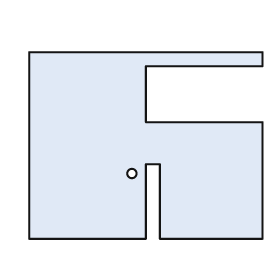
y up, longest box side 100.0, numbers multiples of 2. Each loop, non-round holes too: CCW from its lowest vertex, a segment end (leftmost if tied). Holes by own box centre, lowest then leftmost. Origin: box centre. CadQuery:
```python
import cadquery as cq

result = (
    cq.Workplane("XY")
    .moveTo(-50.0, -40.0)
    .lineTo(0.0, -40.0)
    .lineTo(0.0, -8.0)
    .lineTo(6.0, -8.0)
    .lineTo(6.0, -40.0)
    .lineTo(50.0, -40.0)
    .lineTo(50.0, 10.0)
    .lineTo(0.0, 10.0)
    .lineTo(0.0, 34.0)
    .lineTo(50.0, 34.0)
    .lineTo(50.0, 40.0)
    .lineTo(-50.0, 40.0)
    .close()
    .moveTo(-6.0, -12.0)
    .circle(2.0)
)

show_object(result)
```